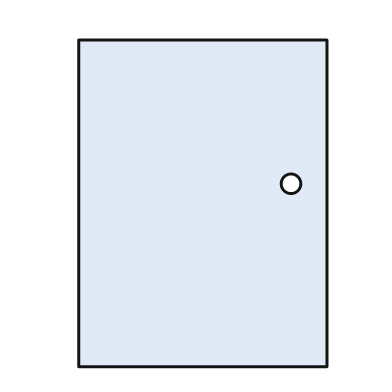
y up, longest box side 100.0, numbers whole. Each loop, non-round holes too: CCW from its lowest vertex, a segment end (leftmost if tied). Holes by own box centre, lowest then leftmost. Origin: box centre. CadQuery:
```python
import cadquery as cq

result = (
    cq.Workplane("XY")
    .moveTo(-38.0, -50.0)
    .lineTo(38.0, -50.0)
    .lineTo(38.0, 50.0)
    .lineTo(-38.0, 50.0)
    .close()
    .moveTo(27.0, 6.0)
    .circle(3.0)
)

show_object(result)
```